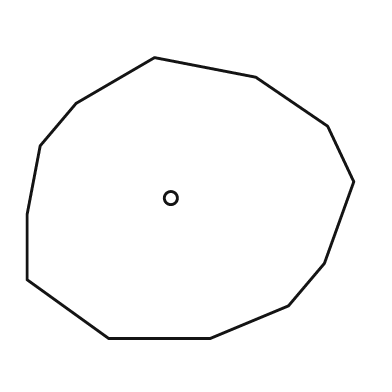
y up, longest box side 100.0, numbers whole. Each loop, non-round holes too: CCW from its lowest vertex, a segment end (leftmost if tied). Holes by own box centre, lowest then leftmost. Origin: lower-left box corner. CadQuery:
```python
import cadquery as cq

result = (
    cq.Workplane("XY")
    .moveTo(25.0, 0.0)
    .lineTo(56.0, 0.0)
    .lineTo(80.0, 10.0)
    .lineTo(91.0, 23.0)
    .lineTo(100.0, 48.0)
    .lineTo(92.0, 65.0)
    .lineTo(70.0, 80.0)
    .lineTo(39.0, 86.0)
    .lineTo(15.0, 72.0)
    .lineTo(4.0, 59.0)
    .lineTo(0.0, 38.0)
    .lineTo(0.0, 18.0)
    .close()
    .moveTo(44.0, 43.0)
    .circle(2.0)
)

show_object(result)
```